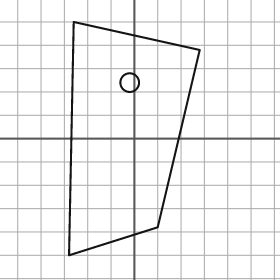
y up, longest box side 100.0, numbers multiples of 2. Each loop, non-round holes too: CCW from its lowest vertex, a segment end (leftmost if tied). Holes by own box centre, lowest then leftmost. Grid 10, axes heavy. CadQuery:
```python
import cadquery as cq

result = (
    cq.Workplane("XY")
    .moveTo(-28.0, -50.0)
    .lineTo(10.0, -38.0)
    .lineTo(28.0, 38.0)
    .lineTo(-26.0, 50.0)
    .close()
    .moveTo(-2.0, 24.0)
    .circle(4.0)
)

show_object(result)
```